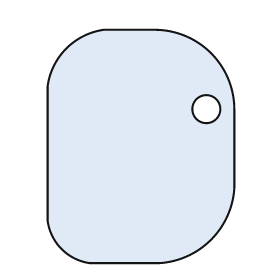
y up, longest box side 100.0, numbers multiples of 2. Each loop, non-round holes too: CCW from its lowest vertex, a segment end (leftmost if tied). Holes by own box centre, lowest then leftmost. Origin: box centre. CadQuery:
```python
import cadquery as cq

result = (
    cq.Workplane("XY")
    .moveTo(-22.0, -50.0)
    .lineTo(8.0, -50.0)
    .threePointArc((30.0, -40.0), (40.0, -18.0))
    .lineTo(40.0, 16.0)
    .threePointArc((30.0, 40.0), (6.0, 50.0))
    .lineTo(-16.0, 50.0)
    .threePointArc((-32.0, 42.0), (-40.0, 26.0))
    .lineTo(-40.0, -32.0)
    .threePointArc((-34.0, -44.0), (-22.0, -50.0))
    .close()
    .moveTo(28.0, 16.0)
    .circle(6.0)
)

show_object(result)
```